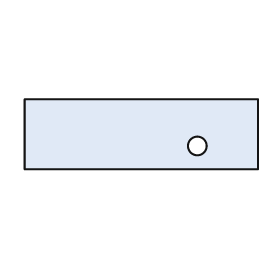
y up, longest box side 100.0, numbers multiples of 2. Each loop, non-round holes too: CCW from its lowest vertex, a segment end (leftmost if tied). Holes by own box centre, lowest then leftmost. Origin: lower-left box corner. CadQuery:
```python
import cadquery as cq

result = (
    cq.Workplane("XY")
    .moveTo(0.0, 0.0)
    .lineTo(100.0, 0.0)
    .lineTo(100.0, 30.0)
    .lineTo(0.0, 30.0)
    .close()
    .moveTo(74.0, 10.0)
    .circle(4.0)
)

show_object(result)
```